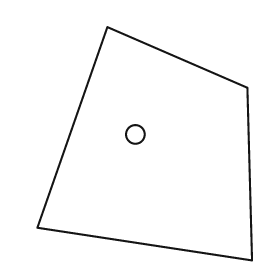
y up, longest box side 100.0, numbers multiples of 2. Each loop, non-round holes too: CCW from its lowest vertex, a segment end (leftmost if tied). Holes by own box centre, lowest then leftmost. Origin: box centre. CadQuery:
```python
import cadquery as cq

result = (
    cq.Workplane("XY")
    .moveTo(46.0, -50.0)
    .lineTo(44.0, 24.0)
    .lineTo(-16.0, 50.0)
    .lineTo(-46.0, -36.0)
    .close()
    .moveTo(-4.0, 4.0)
    .circle(4.0)
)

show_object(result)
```